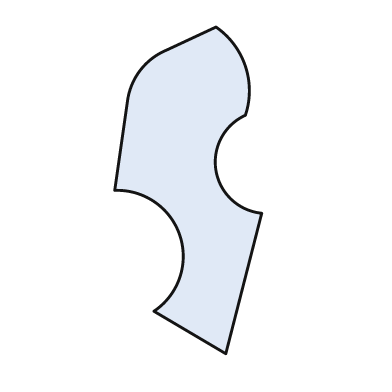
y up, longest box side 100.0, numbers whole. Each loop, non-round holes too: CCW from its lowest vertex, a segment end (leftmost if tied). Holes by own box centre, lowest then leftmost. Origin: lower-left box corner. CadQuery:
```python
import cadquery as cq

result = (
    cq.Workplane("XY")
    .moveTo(34.0, 0.0)
    .lineTo(45.0, 43.0)
    .threePointArc((31.0, 56.0), (40.0, 73.0))
    .threePointArc((40.0, 88.0), (31.0, 100.0))
    .lineTo(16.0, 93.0)
    .threePointArc((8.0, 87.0), (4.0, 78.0))
    .lineTo(0.0, 50.0)
    .threePointArc((20.0, 36.0), (12.0, 13.0))
    .close()
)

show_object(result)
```